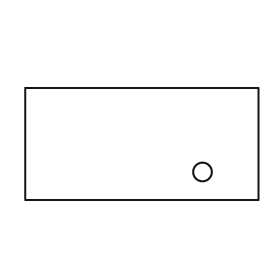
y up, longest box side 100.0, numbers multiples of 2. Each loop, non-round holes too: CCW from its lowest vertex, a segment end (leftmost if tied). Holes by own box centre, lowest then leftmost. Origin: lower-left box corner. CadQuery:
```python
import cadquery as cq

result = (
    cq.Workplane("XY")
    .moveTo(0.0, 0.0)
    .lineTo(100.0, 0.0)
    .lineTo(100.0, 48.0)
    .lineTo(0.0, 48.0)
    .close()
    .moveTo(76.0, 12.0)
    .circle(4.0)
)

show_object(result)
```